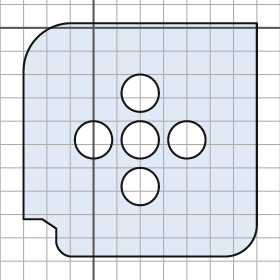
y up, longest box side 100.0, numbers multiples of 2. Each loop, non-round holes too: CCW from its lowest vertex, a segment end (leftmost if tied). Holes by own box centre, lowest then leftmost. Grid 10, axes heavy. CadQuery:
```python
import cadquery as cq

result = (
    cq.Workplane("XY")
    .moveTo(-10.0, -98.0)
    .lineTo(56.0, -98.0)
    .threePointArc((66.0, -94.0), (70.0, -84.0))
    .lineTo(70.0, 2.0)
    .lineTo(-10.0, 2.0)
    .threePointArc((-24.0, -4.0), (-30.0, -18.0))
    .lineTo(-30.0, -82.0)
    .lineTo(-22.0, -82.0)
    .lineTo(-16.0, -86.0)
    .lineTo(-16.0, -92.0)
    .threePointArc((-14.0, -96.0), (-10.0, -98.0))
    .close()
    .moveTo(20.0, -68.0)
    .circle(8.0)
    .moveTo(0.0, -48.0)
    .circle(8.0)
    .moveTo(20.0, -48.0)
    .circle(8.0)
    .moveTo(40.0, -48.0)
    .circle(8.0)
    .moveTo(20.0, -28.0)
    .circle(8.0)
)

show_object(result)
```